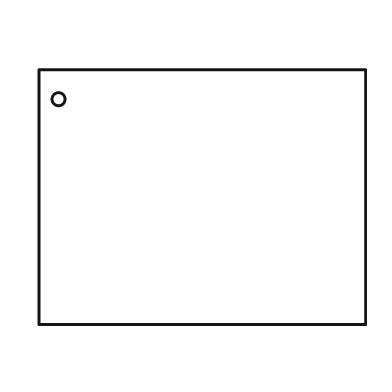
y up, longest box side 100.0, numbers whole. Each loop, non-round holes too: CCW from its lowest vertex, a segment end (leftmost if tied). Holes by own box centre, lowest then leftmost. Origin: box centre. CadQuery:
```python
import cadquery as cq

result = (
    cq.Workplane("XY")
    .moveTo(-50.0, -39.0)
    .lineTo(50.0, -39.0)
    .lineTo(50.0, 39.0)
    .lineTo(-50.0, 39.0)
    .close()
    .moveTo(-44.0, 30.0)
    .circle(2.0)
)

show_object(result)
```